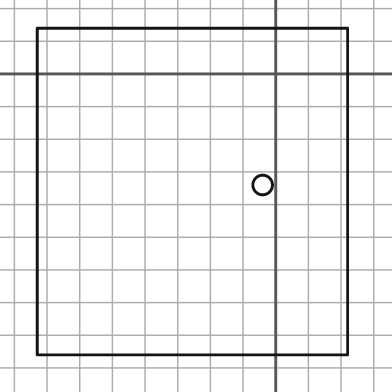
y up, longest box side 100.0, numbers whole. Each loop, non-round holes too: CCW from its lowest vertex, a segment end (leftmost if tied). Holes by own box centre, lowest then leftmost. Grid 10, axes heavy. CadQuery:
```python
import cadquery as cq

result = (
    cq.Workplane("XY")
    .moveTo(-73.0, -86.0)
    .lineTo(22.0, -86.0)
    .lineTo(22.0, 14.0)
    .lineTo(-73.0, 14.0)
    .close()
    .moveTo(-4.0, -34.0)
    .circle(3.0)
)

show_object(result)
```